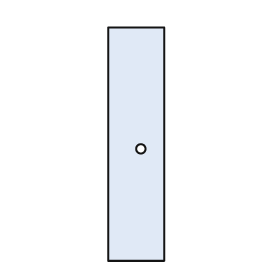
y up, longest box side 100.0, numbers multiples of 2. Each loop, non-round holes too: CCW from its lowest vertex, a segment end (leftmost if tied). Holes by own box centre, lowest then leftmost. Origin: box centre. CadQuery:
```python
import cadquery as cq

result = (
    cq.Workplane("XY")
    .moveTo(-12.0, -50.0)
    .lineTo(12.0, -50.0)
    .lineTo(12.0, 50.0)
    .lineTo(-12.0, 50.0)
    .close()
    .moveTo(2.0, -2.0)
    .circle(2.0)
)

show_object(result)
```